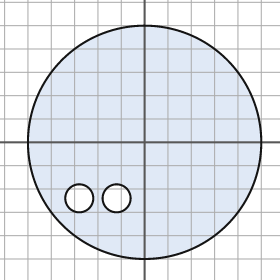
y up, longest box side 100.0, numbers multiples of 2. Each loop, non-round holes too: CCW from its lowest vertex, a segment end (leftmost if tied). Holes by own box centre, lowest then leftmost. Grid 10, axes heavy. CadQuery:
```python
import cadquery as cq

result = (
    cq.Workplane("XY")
    .moveTo(0.0, 0.0)
    .circle(50.0)
    .moveTo(-28.0, -24.0)
    .circle(6.0)
    .moveTo(-12.0, -24.0)
    .circle(6.0)
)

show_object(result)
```